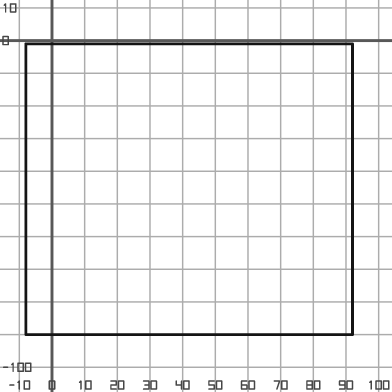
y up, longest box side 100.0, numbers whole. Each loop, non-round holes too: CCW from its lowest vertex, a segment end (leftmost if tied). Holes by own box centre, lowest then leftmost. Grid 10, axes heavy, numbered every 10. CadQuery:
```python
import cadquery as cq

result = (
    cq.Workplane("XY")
    .moveTo(-8.0, -90.0)
    .lineTo(92.0, -90.0)
    .lineTo(92.0, -1.0)
    .lineTo(-8.0, -1.0)
    .close()
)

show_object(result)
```